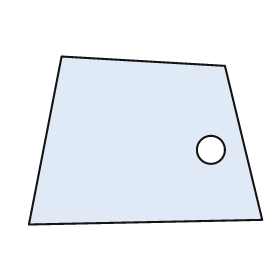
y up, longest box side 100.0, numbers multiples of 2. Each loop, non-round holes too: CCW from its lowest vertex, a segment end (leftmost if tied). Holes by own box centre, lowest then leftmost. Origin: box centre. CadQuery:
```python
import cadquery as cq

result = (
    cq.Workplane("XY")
    .moveTo(-50.0, -36.0)
    .lineTo(50.0, -34.0)
    .lineTo(34.0, 32.0)
    .lineTo(-36.0, 36.0)
    .close()
    .moveTo(28.0, -4.0)
    .circle(6.0)
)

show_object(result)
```